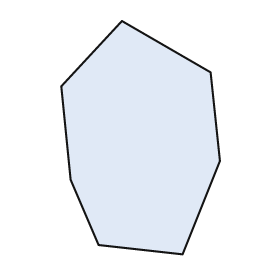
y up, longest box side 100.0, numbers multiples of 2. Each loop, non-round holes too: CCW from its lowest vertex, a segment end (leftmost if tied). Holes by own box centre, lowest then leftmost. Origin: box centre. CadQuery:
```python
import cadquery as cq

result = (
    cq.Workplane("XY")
    .moveTo(18.0, -50.0)
    .lineTo(34.0, -10.0)
    .lineTo(30.0, 28.0)
    .lineTo(-8.0, 50.0)
    .lineTo(-34.0, 22.0)
    .lineTo(-30.0, -18.0)
    .lineTo(-18.0, -46.0)
    .close()
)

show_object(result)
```